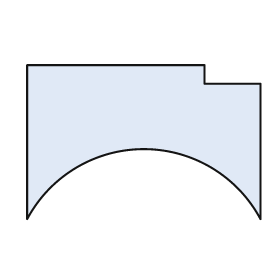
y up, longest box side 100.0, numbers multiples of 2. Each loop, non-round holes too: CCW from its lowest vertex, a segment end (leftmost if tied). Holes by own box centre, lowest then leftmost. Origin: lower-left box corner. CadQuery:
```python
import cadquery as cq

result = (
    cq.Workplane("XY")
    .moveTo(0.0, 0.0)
    .threePointArc((50.0, 30.0), (100.0, 0.0))
    .lineTo(100.0, 58.0)
    .lineTo(76.0, 58.0)
    .lineTo(76.0, 66.0)
    .lineTo(0.0, 66.0)
    .close()
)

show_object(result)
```